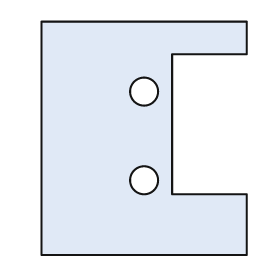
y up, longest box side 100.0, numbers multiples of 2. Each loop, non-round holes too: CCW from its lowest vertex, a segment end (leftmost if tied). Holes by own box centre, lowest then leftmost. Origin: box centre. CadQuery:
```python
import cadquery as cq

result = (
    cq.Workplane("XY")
    .moveTo(-44.0, -50.0)
    .lineTo(44.0, -50.0)
    .lineTo(44.0, -24.0)
    .lineTo(12.0, -24.0)
    .lineTo(12.0, 36.0)
    .lineTo(44.0, 36.0)
    .lineTo(44.0, 50.0)
    .lineTo(-44.0, 50.0)
    .close()
    .moveTo(0.0, -18.0)
    .circle(6.0)
    .moveTo(0.0, 20.0)
    .circle(6.0)
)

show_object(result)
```